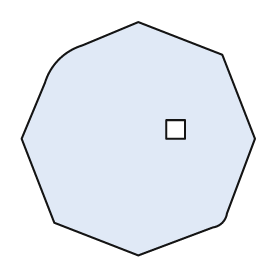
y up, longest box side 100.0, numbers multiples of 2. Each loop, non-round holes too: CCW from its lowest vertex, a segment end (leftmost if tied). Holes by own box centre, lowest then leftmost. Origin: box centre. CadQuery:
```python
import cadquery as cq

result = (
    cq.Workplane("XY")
    .moveTo(0.0, -50.0)
    .lineTo(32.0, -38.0)
    .threePointArc((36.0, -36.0), (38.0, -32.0))
    .lineTo(50.0, 0.0)
    .lineTo(36.0, 36.0)
    .lineTo(0.0, 50.0)
    .lineTo(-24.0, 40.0)
    .threePointArc((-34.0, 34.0), (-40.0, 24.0))
    .lineTo(-50.0, 0.0)
    .lineTo(-36.0, -36.0)
    .close()
    .moveTo(12.0, 0.0)
    .lineTo(20.0, 0.0)
    .lineTo(20.0, 8.0)
    .lineTo(12.0, 8.0)
    .close()
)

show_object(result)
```